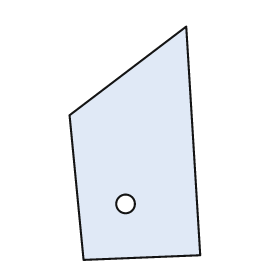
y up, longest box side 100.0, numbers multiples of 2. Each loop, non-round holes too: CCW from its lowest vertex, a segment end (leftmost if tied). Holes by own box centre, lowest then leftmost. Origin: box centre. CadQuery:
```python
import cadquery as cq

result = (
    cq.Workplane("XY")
    .moveTo(-22.0, -50.0)
    .lineTo(28.0, -48.0)
    .lineTo(22.0, 50.0)
    .lineTo(-28.0, 12.0)
    .close()
    .moveTo(-4.0, -26.0)
    .circle(4.0)
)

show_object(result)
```